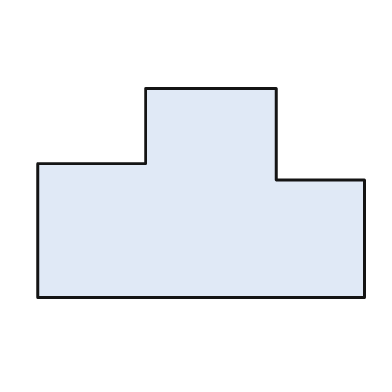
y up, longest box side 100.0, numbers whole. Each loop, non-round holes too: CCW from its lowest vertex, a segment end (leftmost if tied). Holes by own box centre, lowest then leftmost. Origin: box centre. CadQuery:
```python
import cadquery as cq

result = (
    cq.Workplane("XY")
    .moveTo(-50.0, -32.0)
    .lineTo(50.0, -32.0)
    .lineTo(50.0, 4.0)
    .lineTo(23.0, 4.0)
    .lineTo(23.0, 32.0)
    .lineTo(-17.0, 32.0)
    .lineTo(-17.0, 9.0)
    .lineTo(-50.0, 9.0)
    .close()
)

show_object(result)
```